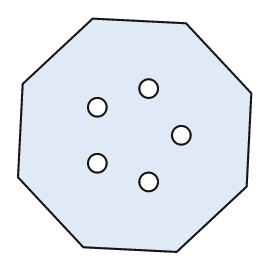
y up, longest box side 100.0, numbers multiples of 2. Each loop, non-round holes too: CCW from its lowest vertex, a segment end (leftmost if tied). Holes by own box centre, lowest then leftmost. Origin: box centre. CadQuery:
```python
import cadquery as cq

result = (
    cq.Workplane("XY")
    .moveTo(18.0, -50.0)
    .lineTo(48.0, -22.0)
    .lineTo(50.0, 18.0)
    .lineTo(22.0, 48.0)
    .lineTo(-18.0, 50.0)
    .lineTo(-48.0, 22.0)
    .lineTo(-50.0, -18.0)
    .lineTo(-22.0, -48.0)
    .close()
    .moveTo(6.0, -20.0)
    .circle(4.0)
    .moveTo(-16.0, -12.0)
    .circle(4.0)
    .moveTo(20.0, 0.0)
    .circle(4.0)
    .moveTo(-16.0, 12.0)
    .circle(4.0)
    .moveTo(6.0, 20.0)
    .circle(4.0)
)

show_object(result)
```